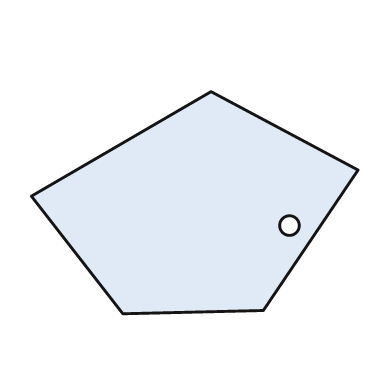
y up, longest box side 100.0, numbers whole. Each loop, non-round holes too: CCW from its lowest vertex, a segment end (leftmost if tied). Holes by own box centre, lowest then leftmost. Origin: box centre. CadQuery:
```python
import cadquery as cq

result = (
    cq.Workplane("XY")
    .moveTo(-22.0, -34.0)
    .lineTo(21.0, -33.0)
    .lineTo(50.0, 10.0)
    .lineTo(5.0, 34.0)
    .lineTo(-50.0, 2.0)
    .close()
    .moveTo(29.0, -7.0)
    .circle(3.0)
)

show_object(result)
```